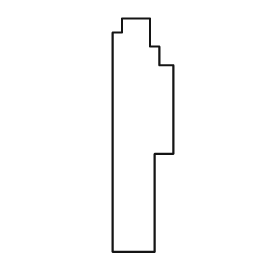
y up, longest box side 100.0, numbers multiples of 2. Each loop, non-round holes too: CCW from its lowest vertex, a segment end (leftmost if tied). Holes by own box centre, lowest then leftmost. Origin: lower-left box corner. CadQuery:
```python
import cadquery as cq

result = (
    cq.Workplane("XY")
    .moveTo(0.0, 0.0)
    .lineTo(18.0, 0.0)
    .lineTo(18.0, 42.0)
    .lineTo(26.0, 42.0)
    .lineTo(26.0, 80.0)
    .lineTo(20.0, 80.0)
    .lineTo(20.0, 88.0)
    .lineTo(16.0, 88.0)
    .lineTo(16.0, 100.0)
    .lineTo(4.0, 100.0)
    .lineTo(4.0, 94.0)
    .lineTo(0.0, 94.0)
    .close()
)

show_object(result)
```